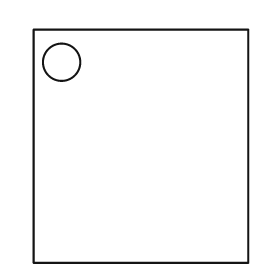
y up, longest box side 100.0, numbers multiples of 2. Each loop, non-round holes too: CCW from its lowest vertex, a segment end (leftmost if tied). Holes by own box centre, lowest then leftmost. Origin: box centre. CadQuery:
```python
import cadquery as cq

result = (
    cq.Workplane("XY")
    .moveTo(-46.0, -50.0)
    .lineTo(46.0, -50.0)
    .lineTo(46.0, 50.0)
    .lineTo(-46.0, 50.0)
    .close()
    .moveTo(-34.0, 36.0)
    .circle(8.0)
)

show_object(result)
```